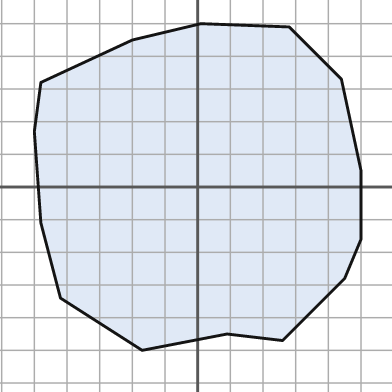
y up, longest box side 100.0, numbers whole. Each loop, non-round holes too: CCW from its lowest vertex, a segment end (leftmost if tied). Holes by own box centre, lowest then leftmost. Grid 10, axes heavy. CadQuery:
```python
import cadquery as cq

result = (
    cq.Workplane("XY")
    .moveTo(-17.0, -50.0)
    .lineTo(9.0, -45.0)
    .lineTo(26.0, -47.0)
    .lineTo(45.0, -28.0)
    .lineTo(50.0, -16.0)
    .lineTo(50.0, 5.0)
    .lineTo(44.0, 33.0)
    .lineTo(28.0, 49.0)
    .lineTo(1.0, 50.0)
    .lineTo(-20.0, 45.0)
    .lineTo(-48.0, 32.0)
    .lineTo(-50.0, 17.0)
    .lineTo(-48.0, -11.0)
    .lineTo(-42.0, -34.0)
    .close()
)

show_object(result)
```